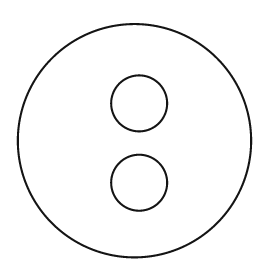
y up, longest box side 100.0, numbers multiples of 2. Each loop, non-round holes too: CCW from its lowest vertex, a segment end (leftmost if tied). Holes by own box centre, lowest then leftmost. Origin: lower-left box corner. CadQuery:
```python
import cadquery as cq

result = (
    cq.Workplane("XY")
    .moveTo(50.0, 50.0)
    .circle(50.0)
    .moveTo(52.0, 32.0)
    .circle(12.0)
    .moveTo(52.0, 66.0)
    .circle(12.0)
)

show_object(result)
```